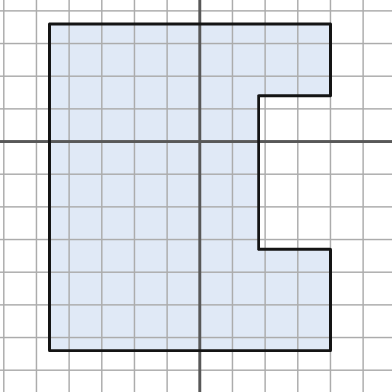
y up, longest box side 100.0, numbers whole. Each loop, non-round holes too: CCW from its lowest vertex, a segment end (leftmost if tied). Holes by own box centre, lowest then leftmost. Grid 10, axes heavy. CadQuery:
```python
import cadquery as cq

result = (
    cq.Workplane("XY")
    .moveTo(-46.0, -64.0)
    .lineTo(40.0, -64.0)
    .lineTo(40.0, -33.0)
    .lineTo(18.0, -33.0)
    .lineTo(18.0, 14.0)
    .lineTo(40.0, 14.0)
    .lineTo(40.0, 36.0)
    .lineTo(-46.0, 36.0)
    .close()
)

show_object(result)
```